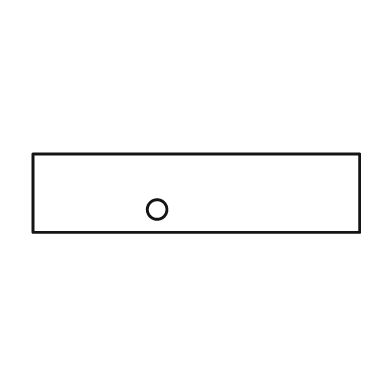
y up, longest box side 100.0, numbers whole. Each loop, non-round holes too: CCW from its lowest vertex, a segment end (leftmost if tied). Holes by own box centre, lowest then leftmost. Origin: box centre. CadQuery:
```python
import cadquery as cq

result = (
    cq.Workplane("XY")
    .moveTo(-50.0, -12.0)
    .lineTo(50.0, -12.0)
    .lineTo(50.0, 12.0)
    .lineTo(-50.0, 12.0)
    .close()
    .moveTo(-12.0, -5.0)
    .circle(3.0)
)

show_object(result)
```